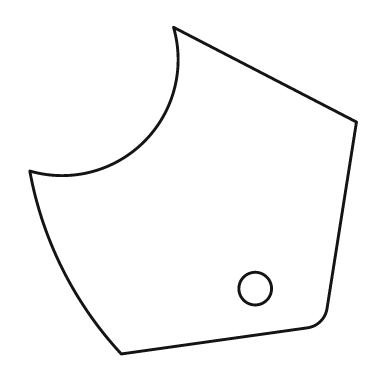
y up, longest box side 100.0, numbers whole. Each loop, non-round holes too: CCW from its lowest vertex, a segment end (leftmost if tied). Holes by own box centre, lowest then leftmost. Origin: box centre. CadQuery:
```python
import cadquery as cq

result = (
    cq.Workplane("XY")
    .moveTo(-22.0, -50.0)
    .lineTo(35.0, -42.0)
    .threePointArc((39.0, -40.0), (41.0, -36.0))
    .lineTo(50.0, 21.0)
    .lineTo(-6.0, 50.0)
    .threePointArc((-15.0, 15.0), (-50.0, 6.0))
    .threePointArc((-40.0, -24.0), (-22.0, -50.0))
    .close()
    .moveTo(19.0, -30.0)
    .circle(5.0)
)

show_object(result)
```